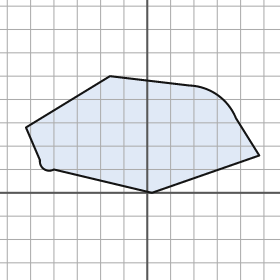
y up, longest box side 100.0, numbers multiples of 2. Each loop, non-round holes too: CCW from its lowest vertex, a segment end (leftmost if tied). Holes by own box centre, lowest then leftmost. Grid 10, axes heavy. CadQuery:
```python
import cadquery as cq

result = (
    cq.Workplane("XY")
    .moveTo(2.0, 0.0)
    .lineTo(48.0, 16.0)
    .lineTo(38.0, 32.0)
    .threePointArc((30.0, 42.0), (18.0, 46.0))
    .lineTo(-16.0, 50.0)
    .lineTo(-52.0, 28.0)
    .lineTo(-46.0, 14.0)
    .threePointArc((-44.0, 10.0), (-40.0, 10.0))
    .close()
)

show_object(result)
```